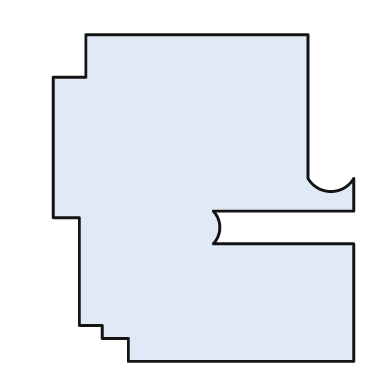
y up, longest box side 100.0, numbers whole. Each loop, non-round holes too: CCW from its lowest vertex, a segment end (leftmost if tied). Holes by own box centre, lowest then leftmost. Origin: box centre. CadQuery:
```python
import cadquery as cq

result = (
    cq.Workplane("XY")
    .moveTo(-23.0, -50.0)
    .lineTo(46.0, -50.0)
    .lineTo(46.0, -14.0)
    .lineTo(3.0, -14.0)
    .threePointArc((5.0, -9.0), (3.0, -4.0))
    .lineTo(46.0, -4.0)
    .lineTo(46.0, 6.0)
    .threePointArc((39.0, 2.0), (32.0, 6.0))
    .lineTo(32.0, 50.0)
    .lineTo(-36.0, 50.0)
    .lineTo(-36.0, 37.0)
    .lineTo(-46.0, 37.0)
    .lineTo(-46.0, -6.0)
    .lineTo(-38.0, -6.0)
    .lineTo(-38.0, -39.0)
    .lineTo(-31.0, -39.0)
    .lineTo(-31.0, -43.0)
    .lineTo(-23.0, -43.0)
    .close()
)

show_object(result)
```